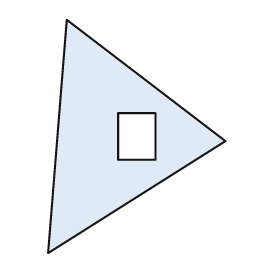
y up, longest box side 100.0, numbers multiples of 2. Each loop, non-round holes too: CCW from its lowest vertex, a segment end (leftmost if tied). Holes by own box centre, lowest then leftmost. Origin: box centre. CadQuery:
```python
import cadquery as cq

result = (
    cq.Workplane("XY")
    .moveTo(-38.0, -50.0)
    .lineTo(38.0, -2.0)
    .lineTo(-30.0, 50.0)
    .close()
    .moveTo(-8.0, -10.0)
    .lineTo(8.0, -10.0)
    .lineTo(8.0, 10.0)
    .lineTo(-8.0, 10.0)
    .close()
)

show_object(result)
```